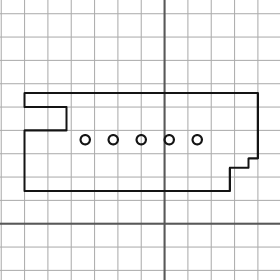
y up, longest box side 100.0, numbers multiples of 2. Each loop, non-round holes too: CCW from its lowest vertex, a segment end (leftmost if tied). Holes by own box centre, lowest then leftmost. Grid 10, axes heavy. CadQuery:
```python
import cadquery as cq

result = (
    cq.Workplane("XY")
    .moveTo(-60.0, 14.0)
    .lineTo(28.0, 14.0)
    .lineTo(28.0, 24.0)
    .lineTo(36.0, 24.0)
    .lineTo(36.0, 28.0)
    .lineTo(40.0, 28.0)
    .lineTo(40.0, 56.0)
    .lineTo(-60.0, 56.0)
    .lineTo(-60.0, 50.0)
    .lineTo(-42.0, 50.0)
    .lineTo(-42.0, 40.0)
    .lineTo(-60.0, 40.0)
    .close()
    .moveTo(-34.0, 36.0)
    .circle(2.0)
    .moveTo(-22.0, 36.0)
    .circle(2.0)
    .moveTo(-10.0, 36.0)
    .circle(2.0)
    .moveTo(2.0, 36.0)
    .circle(2.0)
    .moveTo(14.0, 36.0)
    .circle(2.0)
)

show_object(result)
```